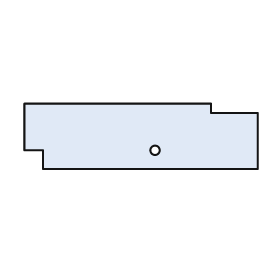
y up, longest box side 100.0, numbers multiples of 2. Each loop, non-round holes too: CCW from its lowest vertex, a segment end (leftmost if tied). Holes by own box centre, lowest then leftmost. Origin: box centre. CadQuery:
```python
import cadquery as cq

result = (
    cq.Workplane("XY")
    .moveTo(-42.0, -14.0)
    .lineTo(50.0, -14.0)
    .lineTo(50.0, 10.0)
    .lineTo(30.0, 10.0)
    .lineTo(30.0, 14.0)
    .lineTo(-50.0, 14.0)
    .lineTo(-50.0, -6.0)
    .lineTo(-42.0, -6.0)
    .close()
    .moveTo(6.0, -6.0)
    .circle(2.0)
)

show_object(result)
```